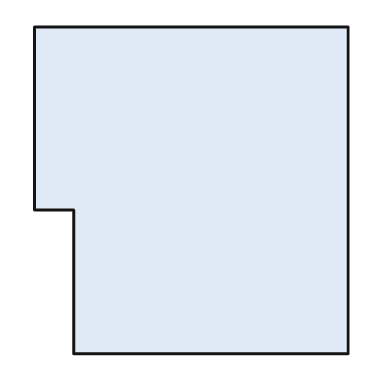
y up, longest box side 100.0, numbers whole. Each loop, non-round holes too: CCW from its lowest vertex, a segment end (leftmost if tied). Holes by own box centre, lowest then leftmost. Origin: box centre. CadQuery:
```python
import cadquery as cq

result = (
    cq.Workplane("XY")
    .moveTo(-36.0, -50.0)
    .lineTo(48.0, -50.0)
    .lineTo(48.0, 50.0)
    .lineTo(-48.0, 50.0)
    .lineTo(-48.0, -6.0)
    .lineTo(-36.0, -6.0)
    .close()
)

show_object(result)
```